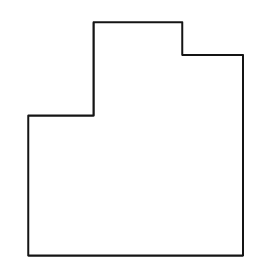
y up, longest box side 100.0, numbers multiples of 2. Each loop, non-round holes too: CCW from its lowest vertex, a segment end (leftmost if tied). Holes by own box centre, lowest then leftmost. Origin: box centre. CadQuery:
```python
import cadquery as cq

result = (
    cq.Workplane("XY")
    .moveTo(-46.0, -50.0)
    .lineTo(46.0, -50.0)
    .lineTo(46.0, 36.0)
    .lineTo(20.0, 36.0)
    .lineTo(20.0, 50.0)
    .lineTo(-18.0, 50.0)
    .lineTo(-18.0, 10.0)
    .lineTo(-46.0, 10.0)
    .close()
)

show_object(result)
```